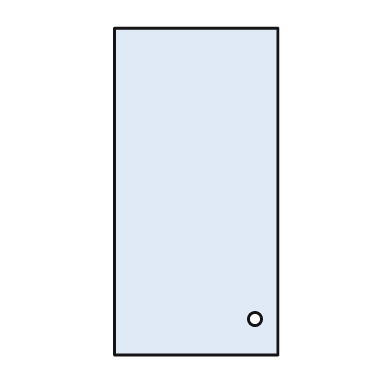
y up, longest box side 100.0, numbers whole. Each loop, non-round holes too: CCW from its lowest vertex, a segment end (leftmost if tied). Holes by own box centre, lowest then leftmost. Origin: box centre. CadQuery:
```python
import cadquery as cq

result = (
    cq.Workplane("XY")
    .moveTo(-25.0, -50.0)
    .lineTo(25.0, -50.0)
    .lineTo(25.0, 50.0)
    .lineTo(-25.0, 50.0)
    .close()
    .moveTo(18.0, -39.0)
    .circle(2.0)
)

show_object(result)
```